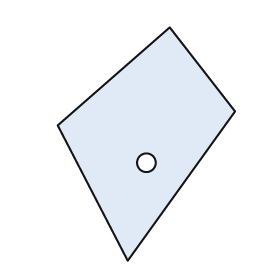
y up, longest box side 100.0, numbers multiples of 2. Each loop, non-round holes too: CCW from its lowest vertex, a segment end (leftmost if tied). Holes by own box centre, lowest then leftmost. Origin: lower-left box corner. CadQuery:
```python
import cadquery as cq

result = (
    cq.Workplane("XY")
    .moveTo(30.0, 0.0)
    .lineTo(76.0, 64.0)
    .lineTo(48.0, 100.0)
    .lineTo(0.0, 58.0)
    .close()
    .moveTo(38.0, 42.0)
    .circle(4.0)
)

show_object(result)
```